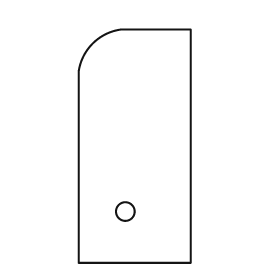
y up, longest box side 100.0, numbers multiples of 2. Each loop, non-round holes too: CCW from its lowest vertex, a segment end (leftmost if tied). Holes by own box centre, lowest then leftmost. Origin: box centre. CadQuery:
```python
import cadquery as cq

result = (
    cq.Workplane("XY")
    .moveTo(-24.0, -50.0)
    .lineTo(24.0, -50.0)
    .lineTo(24.0, 50.0)
    .lineTo(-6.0, 50.0)
    .threePointArc((-18.0, 44.0), (-24.0, 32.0))
    .close()
    .moveTo(-4.0, -28.0)
    .circle(4.0)
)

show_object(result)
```